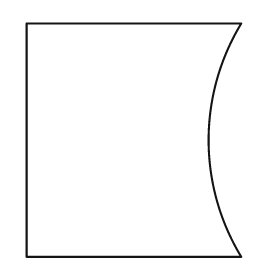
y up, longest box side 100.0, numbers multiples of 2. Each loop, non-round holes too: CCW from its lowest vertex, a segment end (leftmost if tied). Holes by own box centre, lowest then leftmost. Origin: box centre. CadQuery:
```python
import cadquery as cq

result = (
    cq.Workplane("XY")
    .moveTo(-46.0, -50.0)
    .lineTo(46.0, -50.0)
    .threePointArc((32.0, 0.0), (46.0, 50.0))
    .lineTo(-46.0, 50.0)
    .close()
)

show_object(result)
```